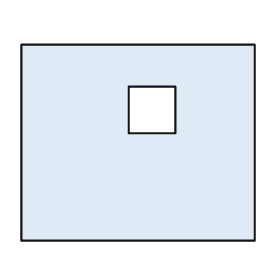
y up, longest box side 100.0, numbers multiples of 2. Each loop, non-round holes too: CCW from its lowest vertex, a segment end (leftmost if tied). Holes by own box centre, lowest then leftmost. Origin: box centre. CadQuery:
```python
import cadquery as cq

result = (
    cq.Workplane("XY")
    .moveTo(-50.0, -42.0)
    .lineTo(50.0, -42.0)
    .lineTo(50.0, 42.0)
    .lineTo(-50.0, 42.0)
    .close()
    .moveTo(-4.0, 4.0)
    .lineTo(16.0, 4.0)
    .lineTo(16.0, 24.0)
    .lineTo(-4.0, 24.0)
    .close()
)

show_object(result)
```